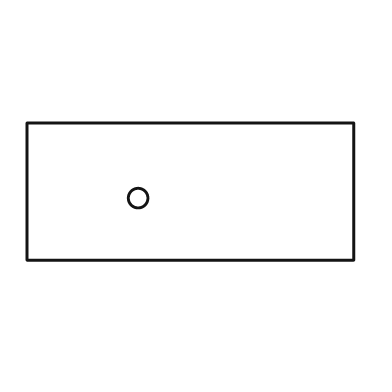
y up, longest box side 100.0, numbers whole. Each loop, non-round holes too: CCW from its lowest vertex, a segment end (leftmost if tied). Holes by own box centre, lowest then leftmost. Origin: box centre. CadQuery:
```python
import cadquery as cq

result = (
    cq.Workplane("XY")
    .moveTo(-50.0, -21.0)
    .lineTo(50.0, -21.0)
    .lineTo(50.0, 21.0)
    .lineTo(-50.0, 21.0)
    .close()
    .moveTo(-16.0, -2.0)
    .circle(3.0)
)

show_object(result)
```